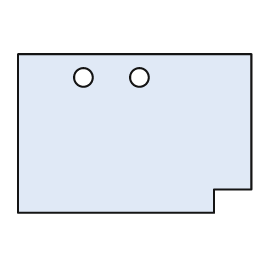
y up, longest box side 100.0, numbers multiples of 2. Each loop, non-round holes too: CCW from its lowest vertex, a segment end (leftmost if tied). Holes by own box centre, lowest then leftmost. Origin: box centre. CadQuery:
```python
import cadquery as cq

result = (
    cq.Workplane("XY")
    .moveTo(-50.0, -34.0)
    .lineTo(34.0, -34.0)
    .lineTo(34.0, -24.0)
    .lineTo(50.0, -24.0)
    .lineTo(50.0, 34.0)
    .lineTo(-50.0, 34.0)
    .close()
    .moveTo(-22.0, 24.0)
    .circle(4.0)
    .moveTo(2.0, 24.0)
    .circle(4.0)
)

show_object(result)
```